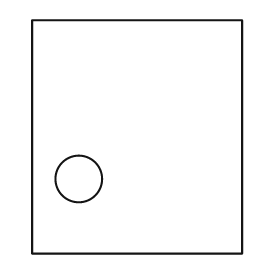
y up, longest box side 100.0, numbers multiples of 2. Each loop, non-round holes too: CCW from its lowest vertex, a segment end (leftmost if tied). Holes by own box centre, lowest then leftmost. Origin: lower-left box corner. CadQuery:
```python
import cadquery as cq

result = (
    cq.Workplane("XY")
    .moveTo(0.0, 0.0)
    .lineTo(90.0, 0.0)
    .lineTo(90.0, 100.0)
    .lineTo(0.0, 100.0)
    .close()
    .moveTo(20.0, 32.0)
    .circle(10.0)
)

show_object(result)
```